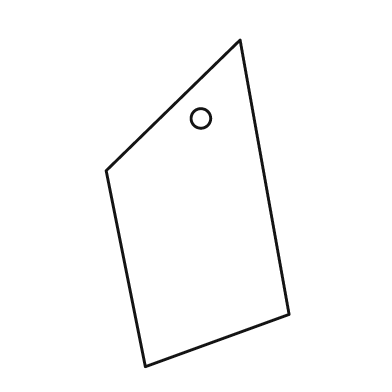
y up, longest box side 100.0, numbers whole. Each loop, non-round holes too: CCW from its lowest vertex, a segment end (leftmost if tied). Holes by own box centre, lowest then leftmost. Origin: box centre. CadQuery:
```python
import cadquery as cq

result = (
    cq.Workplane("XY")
    .moveTo(-16.0, -50.0)
    .lineTo(28.0, -34.0)
    .lineTo(13.0, 50.0)
    .lineTo(-28.0, 10.0)
    .close()
    .moveTo(1.0, 26.0)
    .circle(3.0)
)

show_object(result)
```